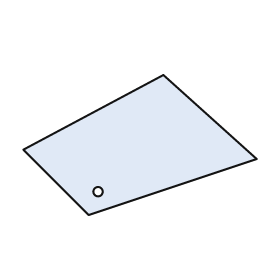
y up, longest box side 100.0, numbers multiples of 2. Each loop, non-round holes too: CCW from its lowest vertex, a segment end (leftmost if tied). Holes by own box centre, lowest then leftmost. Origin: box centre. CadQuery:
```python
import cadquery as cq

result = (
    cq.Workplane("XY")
    .moveTo(-22.0, -30.0)
    .lineTo(50.0, -6.0)
    .lineTo(10.0, 30.0)
    .lineTo(-50.0, -2.0)
    .close()
    .moveTo(-18.0, -20.0)
    .circle(2.0)
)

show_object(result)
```